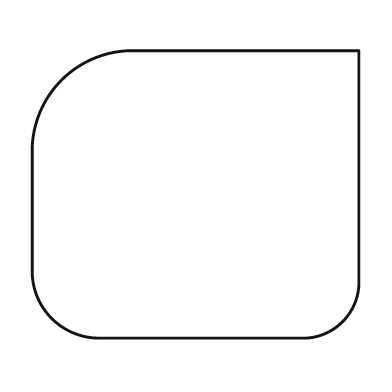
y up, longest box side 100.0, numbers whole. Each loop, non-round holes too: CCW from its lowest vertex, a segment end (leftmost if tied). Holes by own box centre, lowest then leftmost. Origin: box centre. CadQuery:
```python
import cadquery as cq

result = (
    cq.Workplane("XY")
    .moveTo(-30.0, -44.0)
    .lineTo(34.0, -44.0)
    .threePointArc((45.0, -39.0), (50.0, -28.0))
    .lineTo(50.0, 44.0)
    .lineTo(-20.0, 44.0)
    .threePointArc((-41.0, 35.0), (-50.0, 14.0))
    .lineTo(-50.0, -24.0)
    .threePointArc((-44.0, -38.0), (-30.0, -44.0))
    .close()
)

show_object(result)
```